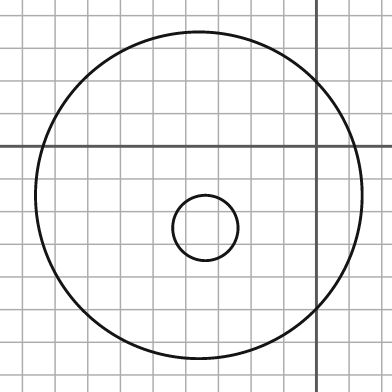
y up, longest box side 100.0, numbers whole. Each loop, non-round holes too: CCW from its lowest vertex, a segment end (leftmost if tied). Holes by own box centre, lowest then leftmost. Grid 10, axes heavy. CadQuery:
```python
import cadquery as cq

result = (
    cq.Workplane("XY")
    .moveTo(-36.0, -15.0)
    .circle(50.0)
    .moveTo(-34.0, -25.0)
    .circle(10.0)
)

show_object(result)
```